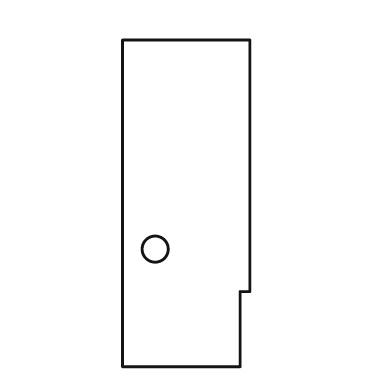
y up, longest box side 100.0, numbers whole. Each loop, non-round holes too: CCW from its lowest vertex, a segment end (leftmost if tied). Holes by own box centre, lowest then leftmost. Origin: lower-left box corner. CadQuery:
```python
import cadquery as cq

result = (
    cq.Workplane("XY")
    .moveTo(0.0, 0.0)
    .lineTo(36.0, 0.0)
    .lineTo(36.0, 23.0)
    .lineTo(39.0, 23.0)
    .lineTo(39.0, 100.0)
    .lineTo(0.0, 100.0)
    .close()
    .moveTo(10.0, 36.0)
    .circle(4.0)
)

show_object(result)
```